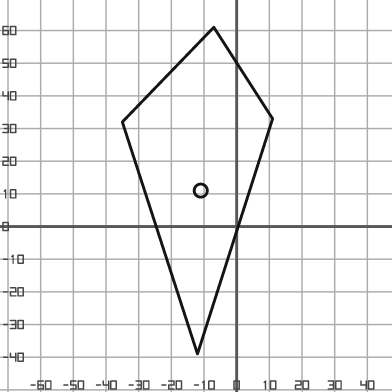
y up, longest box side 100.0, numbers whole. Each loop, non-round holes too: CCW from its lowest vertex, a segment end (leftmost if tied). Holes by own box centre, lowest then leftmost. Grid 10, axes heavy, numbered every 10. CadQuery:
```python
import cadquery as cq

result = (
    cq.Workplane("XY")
    .moveTo(-12.0, -39.0)
    .lineTo(11.0, 33.0)
    .lineTo(-7.0, 61.0)
    .lineTo(-35.0, 32.0)
    .close()
    .moveTo(-11.0, 11.0)
    .circle(2.0)
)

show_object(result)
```